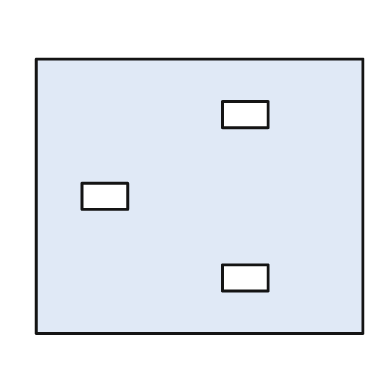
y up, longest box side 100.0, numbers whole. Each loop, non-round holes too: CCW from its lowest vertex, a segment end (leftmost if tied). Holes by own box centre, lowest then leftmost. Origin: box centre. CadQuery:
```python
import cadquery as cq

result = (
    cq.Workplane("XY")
    .moveTo(-50.0, -42.0)
    .lineTo(50.0, -42.0)
    .lineTo(50.0, 42.0)
    .lineTo(-50.0, 42.0)
    .close()
    .moveTo(7.0, -29.0)
    .lineTo(21.0, -29.0)
    .lineTo(21.0, -21.0)
    .lineTo(7.0, -21.0)
    .close()
    .moveTo(-36.0, -4.0)
    .lineTo(-22.0, -4.0)
    .lineTo(-22.0, 4.0)
    .lineTo(-36.0, 4.0)
    .close()
    .moveTo(7.0, 21.0)
    .lineTo(21.0, 21.0)
    .lineTo(21.0, 29.0)
    .lineTo(7.0, 29.0)
    .close()
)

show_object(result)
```